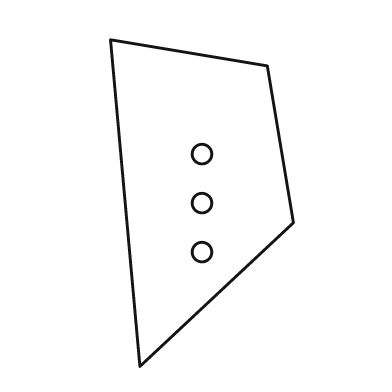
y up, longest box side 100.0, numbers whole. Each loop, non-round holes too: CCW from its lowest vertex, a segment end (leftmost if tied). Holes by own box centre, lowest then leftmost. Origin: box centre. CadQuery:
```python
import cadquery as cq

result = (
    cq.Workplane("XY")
    .moveTo(-19.0, -50.0)
    .lineTo(28.0, -6.0)
    .lineTo(20.0, 42.0)
    .lineTo(-28.0, 50.0)
    .close()
    .moveTo(0.0, -15.0)
    .circle(3.0)
    .moveTo(0.0, 0.0)
    .circle(3.0)
    .moveTo(0.0, 15.0)
    .circle(3.0)
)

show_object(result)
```